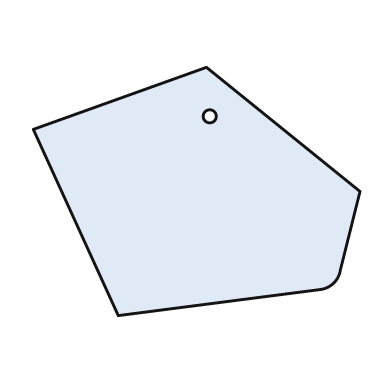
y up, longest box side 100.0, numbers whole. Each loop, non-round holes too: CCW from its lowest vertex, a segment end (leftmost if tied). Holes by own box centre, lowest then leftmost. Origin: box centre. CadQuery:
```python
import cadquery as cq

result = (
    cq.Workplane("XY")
    .moveTo(-24.0, -38.0)
    .lineTo(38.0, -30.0)
    .threePointArc((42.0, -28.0), (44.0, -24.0))
    .lineTo(50.0, 0.0)
    .lineTo(3.0, 38.0)
    .lineTo(-50.0, 19.0)
    .close()
    .moveTo(4.0, 23.0)
    .circle(2.0)
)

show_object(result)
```